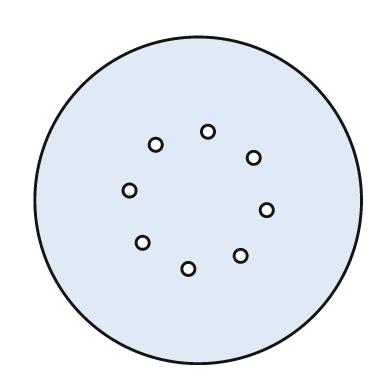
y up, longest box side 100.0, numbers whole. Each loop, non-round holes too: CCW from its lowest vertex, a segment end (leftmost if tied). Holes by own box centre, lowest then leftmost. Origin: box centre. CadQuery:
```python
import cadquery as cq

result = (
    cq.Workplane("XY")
    .moveTo(0.0, 0.0)
    .circle(50.0)
    .moveTo(-3.0, -21.0)
    .circle(2.0)
    .moveTo(13.0, -17.0)
    .circle(2.0)
    .moveTo(-17.0, -13.0)
    .circle(2.0)
    .moveTo(21.0, -3.0)
    .circle(2.0)
    .moveTo(-21.0, 3.0)
    .circle(2.0)
    .moveTo(17.0, 13.0)
    .circle(2.0)
    .moveTo(-13.0, 17.0)
    .circle(2.0)
    .moveTo(3.0, 21.0)
    .circle(2.0)
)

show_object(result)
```